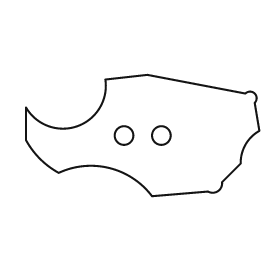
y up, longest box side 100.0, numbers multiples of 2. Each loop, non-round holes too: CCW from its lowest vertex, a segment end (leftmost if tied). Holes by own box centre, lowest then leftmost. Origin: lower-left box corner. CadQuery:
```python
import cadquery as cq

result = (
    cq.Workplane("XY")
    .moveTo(54.0, 0.0)
    .lineTo(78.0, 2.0)
    .threePointArc((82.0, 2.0), (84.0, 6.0))
    .lineTo(92.0, 14.0)
    .threePointArc((94.0, 22.0), (100.0, 28.0))
    .lineTo(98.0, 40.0)
    .threePointArc((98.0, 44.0), (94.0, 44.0))
    .lineTo(52.0, 52.0)
    .lineTo(34.0, 50.0)
    .threePointArc((22.0, 30.0), (0.0, 38.0))
    .lineTo(0.0, 24.0)
    .threePointArc((6.0, 16.0), (14.0, 10.0))
    .threePointArc((36.0, 12.0), (54.0, 0.0))
    .close()
    .moveTo(42.0, 26.0)
    .circle(4.0)
    .moveTo(58.0, 26.0)
    .circle(4.0)
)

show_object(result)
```